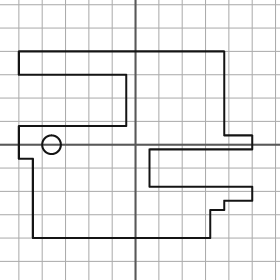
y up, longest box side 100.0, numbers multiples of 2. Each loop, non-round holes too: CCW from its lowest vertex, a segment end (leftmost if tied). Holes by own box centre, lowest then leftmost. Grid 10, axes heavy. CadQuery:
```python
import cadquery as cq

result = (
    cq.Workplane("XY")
    .moveTo(-44.0, -40.0)
    .lineTo(32.0, -40.0)
    .lineTo(32.0, -28.0)
    .lineTo(38.0, -28.0)
    .lineTo(38.0, -24.0)
    .lineTo(50.0, -24.0)
    .lineTo(50.0, -18.0)
    .lineTo(6.0, -18.0)
    .lineTo(6.0, -2.0)
    .lineTo(50.0, -2.0)
    .lineTo(50.0, 4.0)
    .lineTo(38.0, 4.0)
    .lineTo(38.0, 40.0)
    .lineTo(-50.0, 40.0)
    .lineTo(-50.0, 30.0)
    .lineTo(-4.0, 30.0)
    .lineTo(-4.0, 8.0)
    .lineTo(-50.0, 8.0)
    .lineTo(-50.0, -6.0)
    .lineTo(-44.0, -6.0)
    .close()
    .moveTo(-36.0, 0.0)
    .circle(4.0)
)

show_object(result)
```